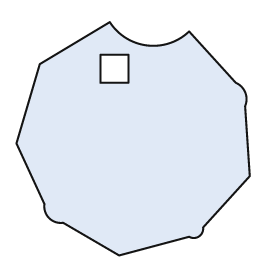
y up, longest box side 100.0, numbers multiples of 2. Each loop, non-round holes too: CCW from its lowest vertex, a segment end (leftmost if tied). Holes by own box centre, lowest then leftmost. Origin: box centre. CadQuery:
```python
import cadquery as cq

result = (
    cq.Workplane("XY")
    .moveTo(-6.0, -50.0)
    .lineTo(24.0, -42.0)
    .threePointArc((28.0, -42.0), (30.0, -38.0))
    .lineTo(50.0, -16.0)
    .lineTo(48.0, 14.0)
    .threePointArc((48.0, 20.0), (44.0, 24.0))
    .lineTo(24.0, 46.0)
    .threePointArc((6.0, 40.0), (-10.0, 50.0))
    .lineTo(-40.0, 32.0)
    .lineTo(-50.0, -2.0)
    .lineTo(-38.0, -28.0)
    .threePointArc((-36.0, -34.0), (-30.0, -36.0))
    .close()
    .moveTo(-14.0, 24.0)
    .lineTo(-2.0, 24.0)
    .lineTo(-2.0, 36.0)
    .lineTo(-14.0, 36.0)
    .close()
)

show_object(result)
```